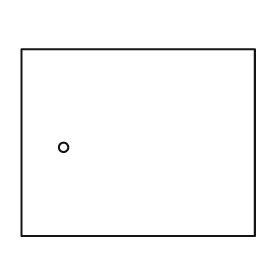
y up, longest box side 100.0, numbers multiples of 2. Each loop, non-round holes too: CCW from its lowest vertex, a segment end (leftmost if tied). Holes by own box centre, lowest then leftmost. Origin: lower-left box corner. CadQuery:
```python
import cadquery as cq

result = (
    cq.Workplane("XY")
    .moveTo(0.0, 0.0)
    .lineTo(100.0, 0.0)
    .lineTo(100.0, 80.0)
    .lineTo(0.0, 80.0)
    .close()
    .moveTo(18.0, 38.0)
    .circle(2.0)
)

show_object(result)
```